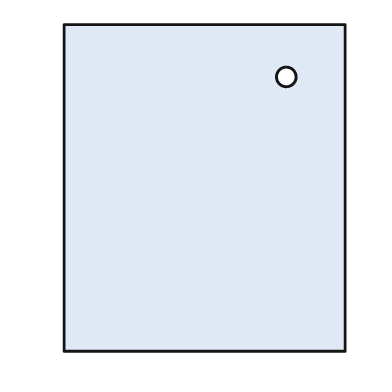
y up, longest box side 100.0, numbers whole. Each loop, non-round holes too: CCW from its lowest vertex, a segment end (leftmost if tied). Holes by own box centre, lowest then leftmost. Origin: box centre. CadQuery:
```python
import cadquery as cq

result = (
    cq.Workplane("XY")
    .moveTo(-43.0, -50.0)
    .lineTo(43.0, -50.0)
    .lineTo(43.0, 50.0)
    .lineTo(-43.0, 50.0)
    .close()
    .moveTo(25.0, 34.0)
    .circle(3.0)
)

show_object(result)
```